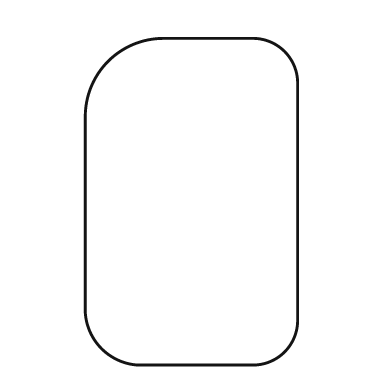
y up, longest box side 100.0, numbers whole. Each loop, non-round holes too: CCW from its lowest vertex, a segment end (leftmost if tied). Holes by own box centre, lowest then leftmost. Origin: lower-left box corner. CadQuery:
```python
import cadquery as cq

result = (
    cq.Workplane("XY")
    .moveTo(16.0, 0.0)
    .lineTo(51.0, 0.0)
    .threePointArc((61.0, 4.0), (65.0, 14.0))
    .lineTo(65.0, 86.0)
    .threePointArc((61.0, 96.0), (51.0, 100.0))
    .lineTo(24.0, 100.0)
    .threePointArc((7.0, 93.0), (0.0, 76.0))
    .lineTo(0.0, 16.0)
    .threePointArc((5.0, 5.0), (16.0, 0.0))
    .close()
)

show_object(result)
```